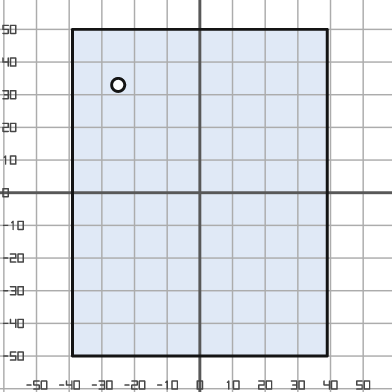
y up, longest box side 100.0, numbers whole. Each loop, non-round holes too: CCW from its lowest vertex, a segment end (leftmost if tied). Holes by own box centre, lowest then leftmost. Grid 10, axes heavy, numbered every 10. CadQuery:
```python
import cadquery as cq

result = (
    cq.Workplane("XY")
    .moveTo(-39.0, -50.0)
    .lineTo(39.0, -50.0)
    .lineTo(39.0, 50.0)
    .lineTo(-39.0, 50.0)
    .close()
    .moveTo(-25.0, 33.0)
    .circle(2.0)
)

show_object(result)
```